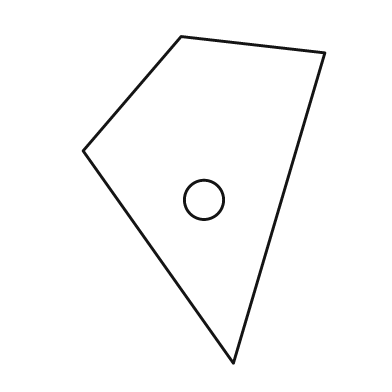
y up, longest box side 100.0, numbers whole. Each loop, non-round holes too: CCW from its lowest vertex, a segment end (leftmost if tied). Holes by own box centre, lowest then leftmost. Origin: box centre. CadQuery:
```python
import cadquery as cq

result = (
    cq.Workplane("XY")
    .moveTo(9.0, -50.0)
    .lineTo(37.0, 45.0)
    .lineTo(-7.0, 50.0)
    .lineTo(-37.0, 15.0)
    .close()
    .moveTo(0.0, 0.0)
    .circle(6.0)
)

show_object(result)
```